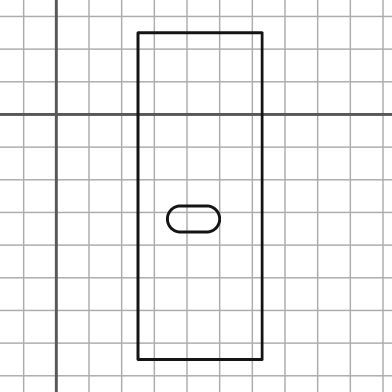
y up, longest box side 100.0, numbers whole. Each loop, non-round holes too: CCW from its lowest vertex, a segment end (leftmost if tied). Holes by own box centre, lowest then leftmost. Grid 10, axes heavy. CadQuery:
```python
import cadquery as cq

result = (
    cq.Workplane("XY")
    .moveTo(25.0, -75.0)
    .lineTo(63.0, -75.0)
    .lineTo(63.0, 25.0)
    .lineTo(25.0, 25.0)
    .close()
    .moveTo(38.0, -36.0)
    .lineTo(46.0, -36.0)
    .threePointArc((50.0, -32.0), (46.0, -28.0))
    .lineTo(38.0, -28.0)
    .threePointArc((34.0, -32.0), (38.0, -36.0))
    .close()
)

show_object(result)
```